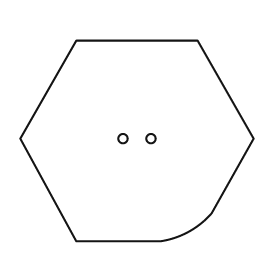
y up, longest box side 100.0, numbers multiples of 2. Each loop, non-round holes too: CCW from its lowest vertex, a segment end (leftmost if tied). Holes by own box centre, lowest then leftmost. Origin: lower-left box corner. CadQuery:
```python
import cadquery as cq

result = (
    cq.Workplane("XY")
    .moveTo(24.0, 0.0)
    .lineTo(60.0, 0.0)
    .threePointArc((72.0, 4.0), (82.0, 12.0))
    .lineTo(100.0, 44.0)
    .lineTo(76.0, 86.0)
    .lineTo(24.0, 86.0)
    .lineTo(0.0, 44.0)
    .close()
    .moveTo(44.0, 44.0)
    .circle(2.0)
    .moveTo(56.0, 44.0)
    .circle(2.0)
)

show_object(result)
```